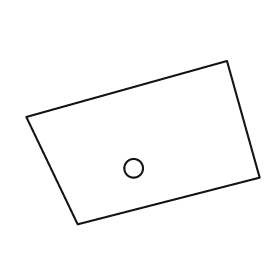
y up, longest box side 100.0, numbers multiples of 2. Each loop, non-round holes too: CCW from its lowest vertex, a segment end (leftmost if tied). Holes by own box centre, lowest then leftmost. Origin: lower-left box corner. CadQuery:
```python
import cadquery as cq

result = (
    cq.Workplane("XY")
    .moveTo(22.0, 0.0)
    .lineTo(100.0, 20.0)
    .lineTo(86.0, 70.0)
    .lineTo(0.0, 46.0)
    .close()
    .moveTo(46.0, 24.0)
    .circle(4.0)
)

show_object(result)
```